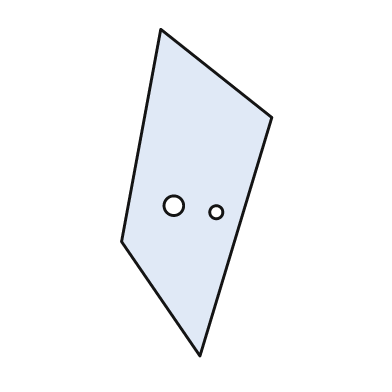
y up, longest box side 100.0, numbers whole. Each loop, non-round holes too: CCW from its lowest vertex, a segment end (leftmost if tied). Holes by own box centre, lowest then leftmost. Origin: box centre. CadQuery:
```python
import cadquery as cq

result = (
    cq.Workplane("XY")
    .moveTo(1.0, -50.0)
    .lineTo(23.0, 23.0)
    .lineTo(-11.0, 50.0)
    .lineTo(-23.0, -15.0)
    .close()
    .moveTo(6.0, -6.0)
    .circle(2.0)
    .moveTo(-7.0, -4.0)
    .circle(3.0)
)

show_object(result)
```